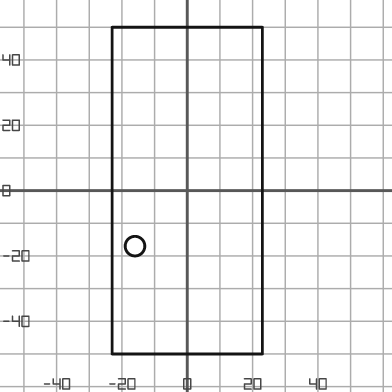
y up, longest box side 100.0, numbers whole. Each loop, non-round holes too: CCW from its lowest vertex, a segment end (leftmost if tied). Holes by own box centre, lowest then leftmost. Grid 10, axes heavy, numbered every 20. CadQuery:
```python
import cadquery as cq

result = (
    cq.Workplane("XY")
    .moveTo(-23.0, -50.0)
    .lineTo(23.0, -50.0)
    .lineTo(23.0, 50.0)
    .lineTo(-23.0, 50.0)
    .close()
    .moveTo(-16.0, -17.0)
    .circle(3.0)
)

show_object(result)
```